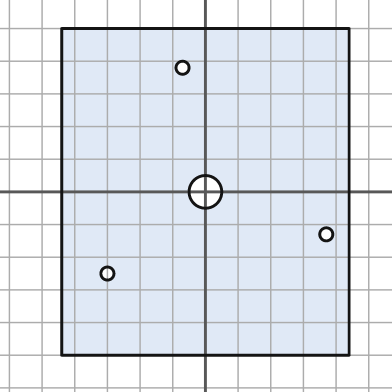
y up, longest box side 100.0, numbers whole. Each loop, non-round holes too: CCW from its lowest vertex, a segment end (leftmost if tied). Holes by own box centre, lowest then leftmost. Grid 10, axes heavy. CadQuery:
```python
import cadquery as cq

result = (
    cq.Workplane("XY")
    .moveTo(-44.0, -50.0)
    .lineTo(44.0, -50.0)
    .lineTo(44.0, 50.0)
    .lineTo(-44.0, 50.0)
    .close()
    .moveTo(-30.0, -25.0)
    .circle(2.0)
    .moveTo(37.0, -13.0)
    .circle(2.0)
    .moveTo(0.0, 0.0)
    .circle(5.0)
    .moveTo(-7.0, 38.0)
    .circle(2.0)
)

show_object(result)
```